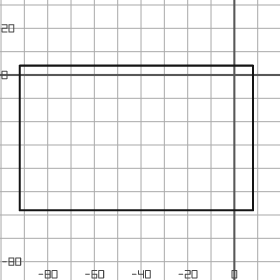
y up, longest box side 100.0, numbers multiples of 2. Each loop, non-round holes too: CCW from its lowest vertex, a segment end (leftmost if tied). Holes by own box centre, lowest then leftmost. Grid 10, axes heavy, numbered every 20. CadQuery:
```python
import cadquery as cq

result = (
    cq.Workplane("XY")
    .moveTo(-92.0, -58.0)
    .lineTo(8.0, -58.0)
    .lineTo(8.0, 4.0)
    .lineTo(-92.0, 4.0)
    .close()
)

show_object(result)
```